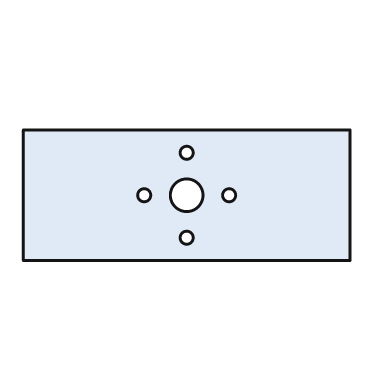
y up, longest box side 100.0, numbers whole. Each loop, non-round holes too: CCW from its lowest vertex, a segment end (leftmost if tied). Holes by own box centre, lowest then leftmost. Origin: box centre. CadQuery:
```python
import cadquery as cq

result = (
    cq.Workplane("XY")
    .moveTo(-50.0, -20.0)
    .lineTo(50.0, -20.0)
    .lineTo(50.0, 20.0)
    .lineTo(-50.0, 20.0)
    .close()
    .moveTo(0.0, -13.0)
    .circle(2.0)
    .moveTo(-13.0, 0.0)
    .circle(2.0)
    .moveTo(0.0, 0.0)
    .circle(5.0)
    .moveTo(13.0, 0.0)
    .circle(2.0)
    .moveTo(0.0, 13.0)
    .circle(2.0)
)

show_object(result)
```